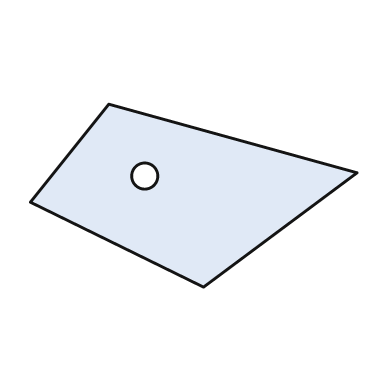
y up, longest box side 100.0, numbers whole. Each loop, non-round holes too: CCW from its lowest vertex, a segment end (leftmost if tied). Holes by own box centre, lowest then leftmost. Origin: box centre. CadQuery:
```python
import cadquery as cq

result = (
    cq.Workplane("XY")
    .moveTo(3.0, -28.0)
    .lineTo(50.0, 7.0)
    .lineTo(-26.0, 28.0)
    .lineTo(-50.0, -2.0)
    .close()
    .moveTo(-15.0, 6.0)
    .circle(4.0)
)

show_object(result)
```